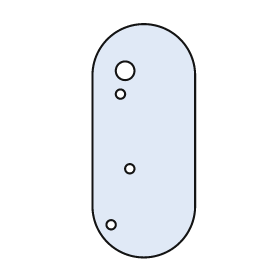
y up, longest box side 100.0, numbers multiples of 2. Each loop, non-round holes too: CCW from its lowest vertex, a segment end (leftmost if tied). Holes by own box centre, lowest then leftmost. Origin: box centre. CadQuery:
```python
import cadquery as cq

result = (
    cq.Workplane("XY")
    .moveTo(-22.0, -28.0)
    .threePointArc((0.0, -50.0), (22.0, -28.0))
    .lineTo(22.0, 28.0)
    .threePointArc((0.0, 50.0), (-22.0, 28.0))
    .close()
    .moveTo(-14.0, -36.0)
    .circle(2.0)
    .moveTo(-6.0, -12.0)
    .circle(2.0)
    .moveTo(-10.0, 20.0)
    .circle(2.0)
    .moveTo(-8.0, 30.0)
    .circle(4.0)
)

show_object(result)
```